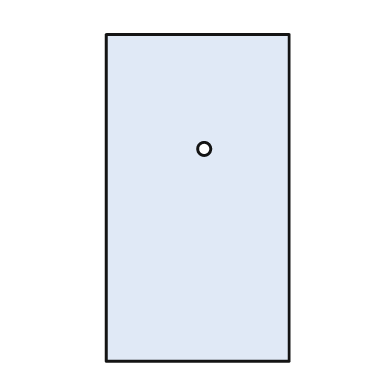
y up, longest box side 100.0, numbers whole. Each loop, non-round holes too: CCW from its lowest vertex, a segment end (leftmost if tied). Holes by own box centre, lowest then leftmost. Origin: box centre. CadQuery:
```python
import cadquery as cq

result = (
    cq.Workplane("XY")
    .moveTo(-28.0, -50.0)
    .lineTo(28.0, -50.0)
    .lineTo(28.0, 50.0)
    .lineTo(-28.0, 50.0)
    .close()
    .moveTo(2.0, 15.0)
    .circle(2.0)
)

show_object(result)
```